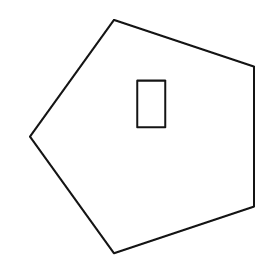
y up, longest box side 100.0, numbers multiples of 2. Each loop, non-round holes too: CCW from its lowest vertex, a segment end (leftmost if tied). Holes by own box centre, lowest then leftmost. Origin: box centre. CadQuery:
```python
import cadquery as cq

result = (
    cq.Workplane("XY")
    .moveTo(-12.0, -50.0)
    .lineTo(48.0, -30.0)
    .lineTo(48.0, 30.0)
    .lineTo(-12.0, 50.0)
    .lineTo(-48.0, 0.0)
    .close()
    .moveTo(-2.0, 4.0)
    .lineTo(10.0, 4.0)
    .lineTo(10.0, 24.0)
    .lineTo(-2.0, 24.0)
    .close()
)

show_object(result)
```